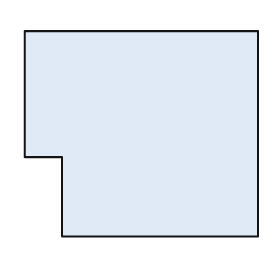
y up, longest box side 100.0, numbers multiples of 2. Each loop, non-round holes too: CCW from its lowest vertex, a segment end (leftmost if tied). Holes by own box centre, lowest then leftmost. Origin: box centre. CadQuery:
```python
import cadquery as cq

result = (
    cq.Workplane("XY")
    .moveTo(-34.0, -44.0)
    .lineTo(50.0, -44.0)
    .lineTo(50.0, 44.0)
    .lineTo(-50.0, 44.0)
    .lineTo(-50.0, -10.0)
    .lineTo(-34.0, -10.0)
    .close()
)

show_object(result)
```